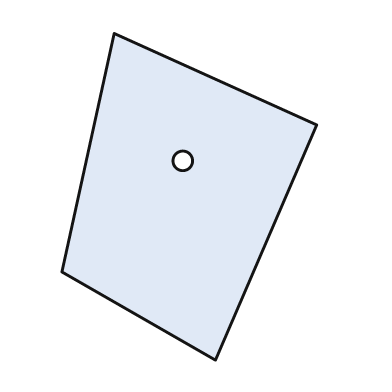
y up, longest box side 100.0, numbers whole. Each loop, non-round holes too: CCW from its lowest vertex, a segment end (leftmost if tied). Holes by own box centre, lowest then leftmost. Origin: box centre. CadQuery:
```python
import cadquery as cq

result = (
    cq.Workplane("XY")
    .moveTo(8.0, -50.0)
    .lineTo(39.0, 22.0)
    .lineTo(-23.0, 50.0)
    .lineTo(-39.0, -23.0)
    .close()
    .moveTo(-2.0, 11.0)
    .circle(3.0)
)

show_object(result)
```